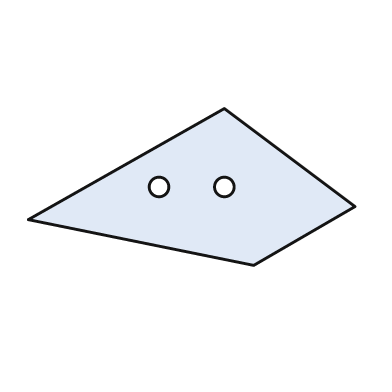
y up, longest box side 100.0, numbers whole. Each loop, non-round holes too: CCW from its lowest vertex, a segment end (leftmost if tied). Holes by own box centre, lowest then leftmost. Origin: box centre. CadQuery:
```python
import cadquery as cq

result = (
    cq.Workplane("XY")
    .moveTo(19.0, -24.0)
    .lineTo(50.0, -6.0)
    .lineTo(10.0, 24.0)
    .lineTo(-50.0, -10.0)
    .close()
    .moveTo(-10.0, 0.0)
    .circle(3.0)
    .moveTo(10.0, 0.0)
    .circle(3.0)
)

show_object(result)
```